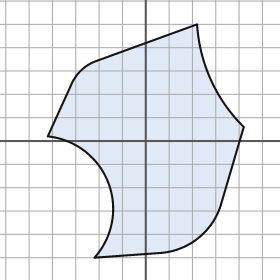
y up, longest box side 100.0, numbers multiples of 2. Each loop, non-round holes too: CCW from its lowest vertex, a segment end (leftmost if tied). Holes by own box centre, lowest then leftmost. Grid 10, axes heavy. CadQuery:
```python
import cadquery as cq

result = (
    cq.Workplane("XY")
    .moveTo(-22.0, -50.0)
    .lineTo(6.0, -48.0)
    .threePointArc((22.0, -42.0), (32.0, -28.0))
    .lineTo(42.0, 6.0)
    .threePointArc((28.0, 26.0), (22.0, 50.0))
    .lineTo(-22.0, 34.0)
    .threePointArc((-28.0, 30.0), (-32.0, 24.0))
    .lineTo(-42.0, 2.0)
    .threePointArc((-16.0, -18.0), (-22.0, -50.0))
    .close()
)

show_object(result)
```